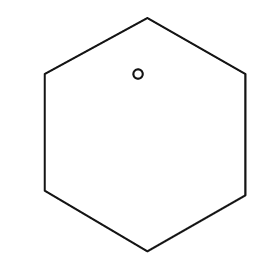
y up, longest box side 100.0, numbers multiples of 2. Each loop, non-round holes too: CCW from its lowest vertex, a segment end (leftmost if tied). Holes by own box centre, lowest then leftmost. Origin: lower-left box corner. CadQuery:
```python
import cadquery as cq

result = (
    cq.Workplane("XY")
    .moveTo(44.0, 0.0)
    .lineTo(86.0, 24.0)
    .lineTo(86.0, 76.0)
    .lineTo(44.0, 100.0)
    .lineTo(0.0, 76.0)
    .lineTo(0.0, 26.0)
    .close()
    .moveTo(40.0, 76.0)
    .circle(2.0)
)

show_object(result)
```